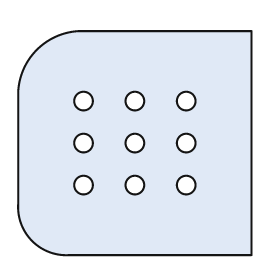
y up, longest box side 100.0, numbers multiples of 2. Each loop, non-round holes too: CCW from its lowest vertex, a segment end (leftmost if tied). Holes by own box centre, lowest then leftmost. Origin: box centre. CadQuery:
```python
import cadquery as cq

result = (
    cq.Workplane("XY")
    .moveTo(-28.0, -48.0)
    .lineTo(50.0, -48.0)
    .lineTo(50.0, 48.0)
    .lineTo(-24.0, 48.0)
    .threePointArc((-42.0, 40.0), (-50.0, 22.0))
    .lineTo(-50.0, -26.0)
    .threePointArc((-44.0, -42.0), (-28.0, -48.0))
    .close()
    .moveTo(-22.0, -18.0)
    .circle(4.0)
    .moveTo(0.0, -18.0)
    .circle(4.0)
    .moveTo(22.0, -18.0)
    .circle(4.0)
    .moveTo(-22.0, 0.0)
    .circle(4.0)
    .moveTo(0.0, 0.0)
    .circle(4.0)
    .moveTo(22.0, 0.0)
    .circle(4.0)
    .moveTo(-22.0, 18.0)
    .circle(4.0)
    .moveTo(0.0, 18.0)
    .circle(4.0)
    .moveTo(22.0, 18.0)
    .circle(4.0)
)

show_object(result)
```